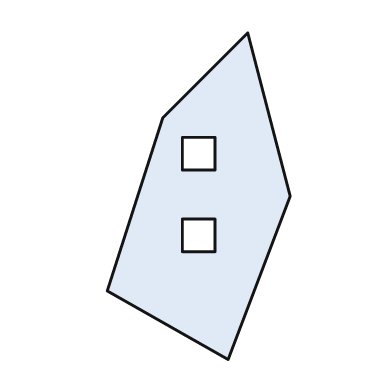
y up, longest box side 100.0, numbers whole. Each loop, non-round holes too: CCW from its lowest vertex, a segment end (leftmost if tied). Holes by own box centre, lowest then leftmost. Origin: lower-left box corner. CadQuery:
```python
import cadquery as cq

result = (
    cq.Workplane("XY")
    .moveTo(37.0, 0.0)
    .lineTo(56.0, 50.0)
    .lineTo(43.0, 100.0)
    .lineTo(17.0, 74.0)
    .lineTo(0.0, 21.0)
    .close()
    .moveTo(23.0, 33.0)
    .lineTo(33.0, 33.0)
    .lineTo(33.0, 43.0)
    .lineTo(23.0, 43.0)
    .close()
    .moveTo(23.0, 58.0)
    .lineTo(33.0, 58.0)
    .lineTo(33.0, 68.0)
    .lineTo(23.0, 68.0)
    .close()
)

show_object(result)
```